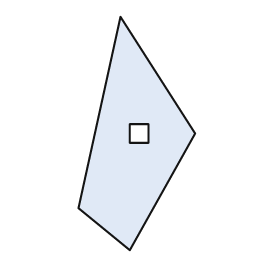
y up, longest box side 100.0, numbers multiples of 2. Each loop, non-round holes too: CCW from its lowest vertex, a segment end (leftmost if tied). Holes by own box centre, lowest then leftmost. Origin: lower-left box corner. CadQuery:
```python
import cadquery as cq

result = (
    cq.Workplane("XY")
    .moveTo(22.0, 0.0)
    .lineTo(50.0, 50.0)
    .lineTo(18.0, 100.0)
    .lineTo(0.0, 18.0)
    .close()
    .moveTo(22.0, 46.0)
    .lineTo(30.0, 46.0)
    .lineTo(30.0, 54.0)
    .lineTo(22.0, 54.0)
    .close()
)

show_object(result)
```